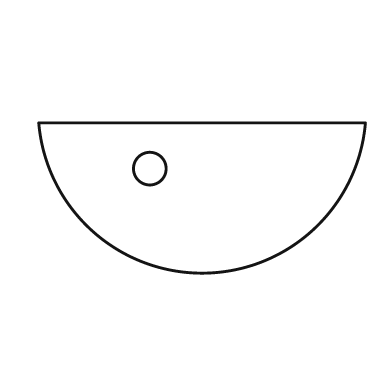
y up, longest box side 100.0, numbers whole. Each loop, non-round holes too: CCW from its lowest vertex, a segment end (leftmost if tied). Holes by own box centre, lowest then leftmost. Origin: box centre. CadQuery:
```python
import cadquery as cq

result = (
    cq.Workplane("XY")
    .moveTo(-50.0, 23.0)
    .threePointArc((0.0, -23.0), (50.0, 23.0))
    .close()
    .moveTo(-16.0, 9.0)
    .circle(5.0)
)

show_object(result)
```